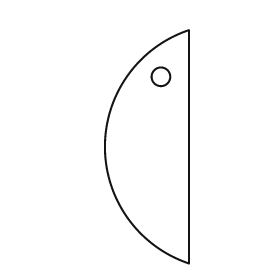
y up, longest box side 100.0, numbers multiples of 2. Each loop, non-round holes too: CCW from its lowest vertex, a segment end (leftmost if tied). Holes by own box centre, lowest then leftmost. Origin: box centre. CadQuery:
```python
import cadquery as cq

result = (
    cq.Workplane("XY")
    .moveTo(18.0, -50.0)
    .lineTo(18.0, 50.0)
    .threePointArc((-18.0, 0.0), (18.0, -50.0))
    .close()
    .moveTo(6.0, 30.0)
    .circle(4.0)
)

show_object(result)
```